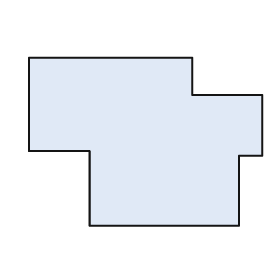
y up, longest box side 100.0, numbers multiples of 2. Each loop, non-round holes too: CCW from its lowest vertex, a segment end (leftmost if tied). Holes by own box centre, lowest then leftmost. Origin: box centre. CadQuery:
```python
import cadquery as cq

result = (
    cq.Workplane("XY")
    .moveTo(-24.0, -36.0)
    .lineTo(40.0, -36.0)
    .lineTo(40.0, -6.0)
    .lineTo(50.0, -6.0)
    .lineTo(50.0, 20.0)
    .lineTo(20.0, 20.0)
    .lineTo(20.0, 36.0)
    .lineTo(-50.0, 36.0)
    .lineTo(-50.0, -4.0)
    .lineTo(-24.0, -4.0)
    .close()
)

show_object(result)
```